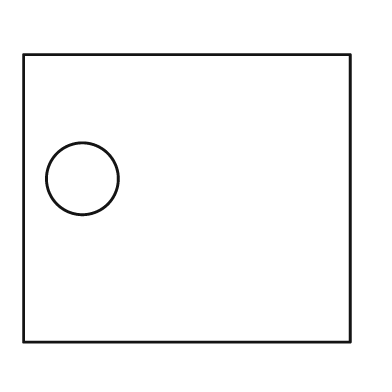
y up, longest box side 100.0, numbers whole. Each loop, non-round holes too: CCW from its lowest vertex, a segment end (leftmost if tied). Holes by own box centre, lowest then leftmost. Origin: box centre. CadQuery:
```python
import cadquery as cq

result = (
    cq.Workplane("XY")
    .moveTo(-50.0, -44.0)
    .lineTo(50.0, -44.0)
    .lineTo(50.0, 44.0)
    .lineTo(-50.0, 44.0)
    .close()
    .moveTo(-32.0, 6.0)
    .circle(11.0)
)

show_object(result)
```